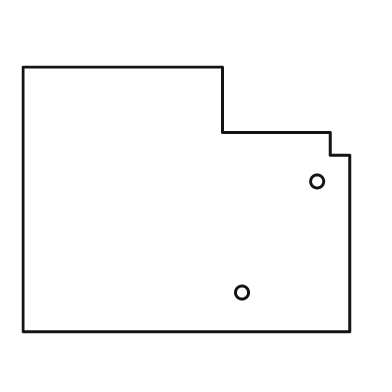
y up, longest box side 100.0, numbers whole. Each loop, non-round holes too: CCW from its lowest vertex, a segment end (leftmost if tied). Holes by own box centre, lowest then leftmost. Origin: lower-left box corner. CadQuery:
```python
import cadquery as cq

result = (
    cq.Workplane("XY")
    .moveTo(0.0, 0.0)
    .lineTo(100.0, 0.0)
    .lineTo(100.0, 54.0)
    .lineTo(94.0, 54.0)
    .lineTo(94.0, 61.0)
    .lineTo(61.0, 61.0)
    .lineTo(61.0, 81.0)
    .lineTo(0.0, 81.0)
    .close()
    .moveTo(67.0, 12.0)
    .circle(2.0)
    .moveTo(90.0, 46.0)
    .circle(2.0)
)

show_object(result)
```